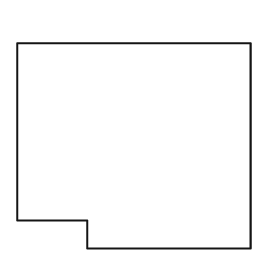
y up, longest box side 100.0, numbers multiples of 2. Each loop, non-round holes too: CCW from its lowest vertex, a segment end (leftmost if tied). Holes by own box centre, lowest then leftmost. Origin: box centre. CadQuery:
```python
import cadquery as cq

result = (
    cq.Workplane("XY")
    .moveTo(-20.0, -44.0)
    .lineTo(50.0, -44.0)
    .lineTo(50.0, 44.0)
    .lineTo(-50.0, 44.0)
    .lineTo(-50.0, -32.0)
    .lineTo(-20.0, -32.0)
    .close()
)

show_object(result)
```